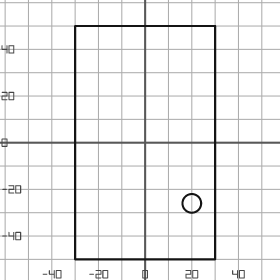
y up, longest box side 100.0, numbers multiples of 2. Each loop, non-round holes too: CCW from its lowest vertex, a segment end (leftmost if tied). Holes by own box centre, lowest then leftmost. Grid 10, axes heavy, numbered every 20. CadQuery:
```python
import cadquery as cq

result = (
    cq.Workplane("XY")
    .moveTo(-30.0, -50.0)
    .lineTo(30.0, -50.0)
    .lineTo(30.0, 50.0)
    .lineTo(-30.0, 50.0)
    .close()
    .moveTo(20.0, -26.0)
    .circle(4.0)
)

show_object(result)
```